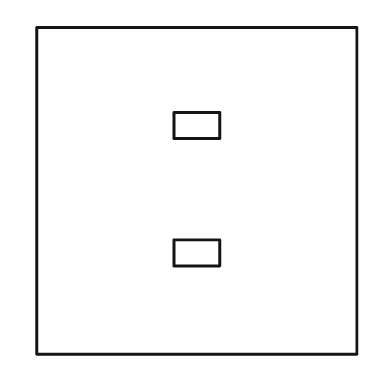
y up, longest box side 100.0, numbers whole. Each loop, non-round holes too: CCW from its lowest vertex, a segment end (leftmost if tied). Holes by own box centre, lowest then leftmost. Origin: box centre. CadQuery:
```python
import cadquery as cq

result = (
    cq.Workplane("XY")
    .moveTo(-49.0, -50.0)
    .lineTo(49.0, -50.0)
    .lineTo(49.0, 50.0)
    .lineTo(-49.0, 50.0)
    .close()
    .moveTo(-7.0, -23.0)
    .lineTo(7.0, -23.0)
    .lineTo(7.0, -15.0)
    .lineTo(-7.0, -15.0)
    .close()
    .moveTo(-7.0, 16.0)
    .lineTo(7.0, 16.0)
    .lineTo(7.0, 24.0)
    .lineTo(-7.0, 24.0)
    .close()
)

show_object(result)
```